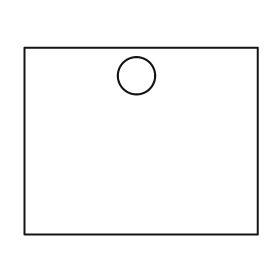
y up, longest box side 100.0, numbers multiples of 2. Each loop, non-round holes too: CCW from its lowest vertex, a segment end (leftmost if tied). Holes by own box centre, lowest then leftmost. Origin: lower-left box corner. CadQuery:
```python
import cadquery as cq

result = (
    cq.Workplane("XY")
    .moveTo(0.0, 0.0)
    .lineTo(100.0, 0.0)
    .lineTo(100.0, 80.0)
    .lineTo(0.0, 80.0)
    .close()
    .moveTo(48.0, 68.0)
    .circle(8.0)
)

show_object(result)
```